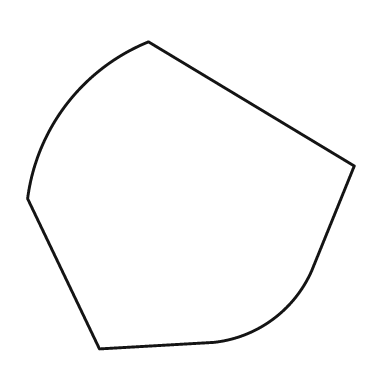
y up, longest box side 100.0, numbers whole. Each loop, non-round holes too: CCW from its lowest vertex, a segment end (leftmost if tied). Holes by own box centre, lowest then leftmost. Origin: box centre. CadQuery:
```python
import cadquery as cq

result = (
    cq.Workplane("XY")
    .moveTo(-28.0, -47.0)
    .lineTo(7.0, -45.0)
    .threePointArc((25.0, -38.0), (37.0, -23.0))
    .lineTo(50.0, 9.0)
    .lineTo(-13.0, 47.0)
    .threePointArc((-38.0, 28.0), (-50.0, -1.0))
    .close()
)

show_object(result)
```